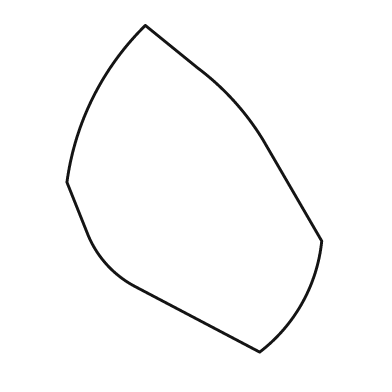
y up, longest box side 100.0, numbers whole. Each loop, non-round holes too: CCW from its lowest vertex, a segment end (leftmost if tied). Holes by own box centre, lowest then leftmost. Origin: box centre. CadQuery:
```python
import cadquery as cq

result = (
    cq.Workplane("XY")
    .moveTo(20.0, -50.0)
    .threePointArc((33.0, -35.0), (39.0, -16.0))
    .lineTo(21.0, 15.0)
    .threePointArc((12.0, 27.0), (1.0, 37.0))
    .lineTo(-15.0, 50.0)
    .threePointArc((-31.0, 28.0), (-39.0, 2.0))
    .lineTo(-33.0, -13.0)
    .threePointArc((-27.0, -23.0), (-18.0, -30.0))
    .close()
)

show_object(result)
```